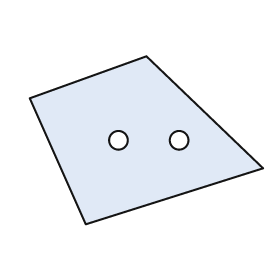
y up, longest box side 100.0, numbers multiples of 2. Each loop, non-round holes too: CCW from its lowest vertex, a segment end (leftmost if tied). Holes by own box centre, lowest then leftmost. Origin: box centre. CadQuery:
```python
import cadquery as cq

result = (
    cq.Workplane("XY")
    .moveTo(-26.0, -36.0)
    .lineTo(50.0, -12.0)
    .lineTo(0.0, 36.0)
    .lineTo(-50.0, 18.0)
    .close()
    .moveTo(-12.0, 0.0)
    .circle(4.0)
    .moveTo(14.0, 0.0)
    .circle(4.0)
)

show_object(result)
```